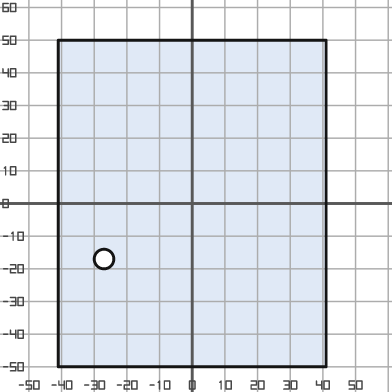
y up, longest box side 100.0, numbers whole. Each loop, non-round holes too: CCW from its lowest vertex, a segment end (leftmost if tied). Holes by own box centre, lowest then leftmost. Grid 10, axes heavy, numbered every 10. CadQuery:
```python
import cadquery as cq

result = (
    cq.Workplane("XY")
    .moveTo(-41.0, -50.0)
    .lineTo(41.0, -50.0)
    .lineTo(41.0, 50.0)
    .lineTo(-41.0, 50.0)
    .close()
    .moveTo(-27.0, -17.0)
    .circle(3.0)
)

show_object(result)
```